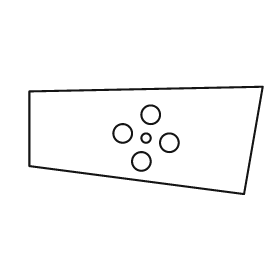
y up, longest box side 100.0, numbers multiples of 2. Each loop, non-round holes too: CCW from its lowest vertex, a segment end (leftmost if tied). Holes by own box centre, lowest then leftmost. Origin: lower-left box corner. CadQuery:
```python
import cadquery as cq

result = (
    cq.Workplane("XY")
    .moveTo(92.0, 0.0)
    .lineTo(100.0, 46.0)
    .lineTo(0.0, 44.0)
    .lineTo(0.0, 12.0)
    .close()
    .moveTo(48.0, 14.0)
    .circle(4.0)
    .moveTo(60.0, 22.0)
    .circle(4.0)
    .moveTo(50.0, 24.0)
    .circle(2.0)
    .moveTo(40.0, 26.0)
    .circle(4.0)
    .moveTo(52.0, 34.0)
    .circle(4.0)
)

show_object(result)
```